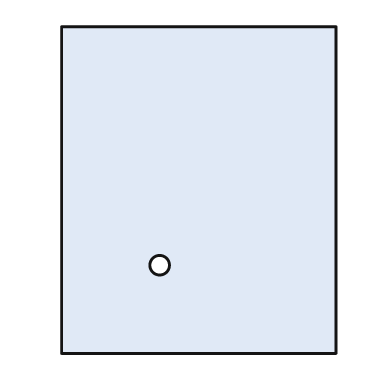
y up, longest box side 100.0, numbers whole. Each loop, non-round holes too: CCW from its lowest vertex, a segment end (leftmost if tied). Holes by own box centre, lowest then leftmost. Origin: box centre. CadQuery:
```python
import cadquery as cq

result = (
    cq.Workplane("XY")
    .moveTo(-42.0, -50.0)
    .lineTo(42.0, -50.0)
    .lineTo(42.0, 50.0)
    .lineTo(-42.0, 50.0)
    .close()
    .moveTo(-12.0, -23.0)
    .circle(3.0)
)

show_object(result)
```